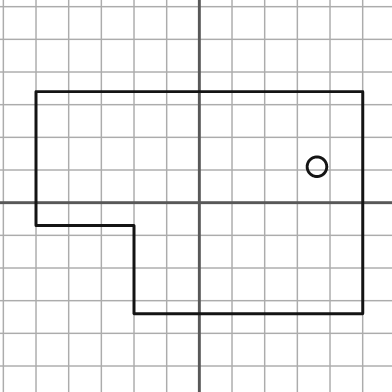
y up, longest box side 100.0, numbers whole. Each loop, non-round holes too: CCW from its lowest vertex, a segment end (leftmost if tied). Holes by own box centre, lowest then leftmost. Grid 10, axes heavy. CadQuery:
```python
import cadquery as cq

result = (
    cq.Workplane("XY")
    .moveTo(-20.0, -34.0)
    .lineTo(50.0, -34.0)
    .lineTo(50.0, 34.0)
    .lineTo(-50.0, 34.0)
    .lineTo(-50.0, -7.0)
    .lineTo(-20.0, -7.0)
    .close()
    .moveTo(36.0, 11.0)
    .circle(3.0)
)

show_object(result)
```